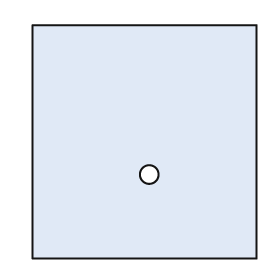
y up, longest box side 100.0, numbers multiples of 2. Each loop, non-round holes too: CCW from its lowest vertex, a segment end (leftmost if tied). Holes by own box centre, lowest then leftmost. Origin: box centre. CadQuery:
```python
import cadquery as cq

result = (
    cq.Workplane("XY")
    .moveTo(-48.0, -50.0)
    .lineTo(48.0, -50.0)
    .lineTo(48.0, 50.0)
    .lineTo(-48.0, 50.0)
    .close()
    .moveTo(2.0, -14.0)
    .circle(4.0)
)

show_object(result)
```